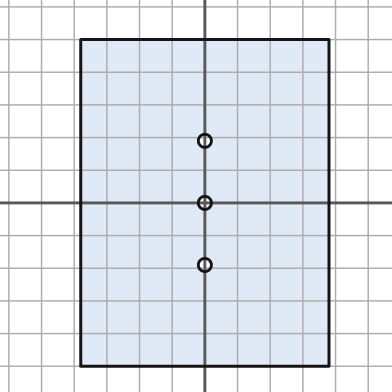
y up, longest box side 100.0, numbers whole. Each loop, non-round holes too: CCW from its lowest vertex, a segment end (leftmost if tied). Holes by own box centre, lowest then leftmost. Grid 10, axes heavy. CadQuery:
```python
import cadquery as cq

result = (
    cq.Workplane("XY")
    .moveTo(-38.0, -50.0)
    .lineTo(38.0, -50.0)
    .lineTo(38.0, 50.0)
    .lineTo(-38.0, 50.0)
    .close()
    .moveTo(0.0, -19.0)
    .circle(2.0)
    .moveTo(0.0, 0.0)
    .circle(2.0)
    .moveTo(0.0, 19.0)
    .circle(2.0)
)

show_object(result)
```